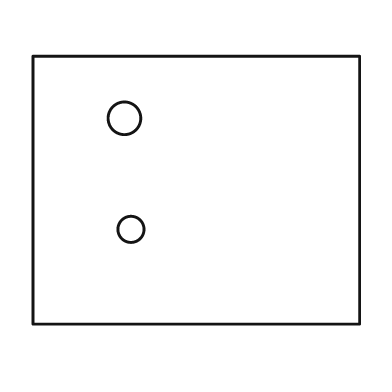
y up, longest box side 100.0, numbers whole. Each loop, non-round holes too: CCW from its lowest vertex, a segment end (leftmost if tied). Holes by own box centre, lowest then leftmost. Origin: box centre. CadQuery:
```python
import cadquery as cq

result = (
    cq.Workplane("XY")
    .moveTo(-50.0, -41.0)
    .lineTo(50.0, -41.0)
    .lineTo(50.0, 41.0)
    .lineTo(-50.0, 41.0)
    .close()
    .moveTo(-20.0, -12.0)
    .circle(4.0)
    .moveTo(-22.0, 22.0)
    .circle(5.0)
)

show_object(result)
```